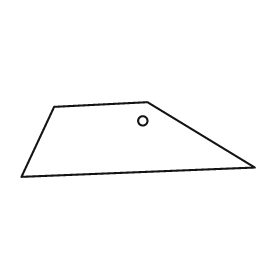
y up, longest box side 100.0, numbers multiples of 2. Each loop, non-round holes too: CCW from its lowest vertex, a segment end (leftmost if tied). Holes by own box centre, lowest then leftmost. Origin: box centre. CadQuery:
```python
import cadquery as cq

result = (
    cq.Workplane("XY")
    .moveTo(-50.0, -16.0)
    .lineTo(50.0, -12.0)
    .lineTo(4.0, 16.0)
    .lineTo(-36.0, 14.0)
    .close()
    .moveTo(2.0, 8.0)
    .circle(2.0)
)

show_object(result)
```